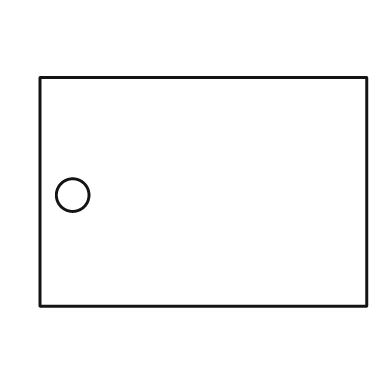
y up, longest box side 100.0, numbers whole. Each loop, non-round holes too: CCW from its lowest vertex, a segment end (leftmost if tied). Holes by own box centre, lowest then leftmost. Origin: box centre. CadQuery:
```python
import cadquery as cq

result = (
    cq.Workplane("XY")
    .moveTo(-50.0, -35.0)
    .lineTo(50.0, -35.0)
    .lineTo(50.0, 35.0)
    .lineTo(-50.0, 35.0)
    .close()
    .moveTo(-40.0, -1.0)
    .circle(5.0)
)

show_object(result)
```